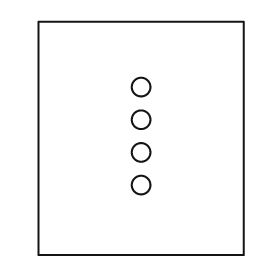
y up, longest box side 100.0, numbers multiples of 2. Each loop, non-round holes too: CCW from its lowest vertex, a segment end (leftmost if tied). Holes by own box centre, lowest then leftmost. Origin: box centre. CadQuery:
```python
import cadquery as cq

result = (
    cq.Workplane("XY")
    .moveTo(-44.0, -50.0)
    .lineTo(44.0, -50.0)
    .lineTo(44.0, 50.0)
    .lineTo(-44.0, 50.0)
    .close()
    .moveTo(0.0, -20.0)
    .circle(4.0)
    .moveTo(0.0, -6.0)
    .circle(4.0)
    .moveTo(0.0, 8.0)
    .circle(4.0)
    .moveTo(0.0, 22.0)
    .circle(4.0)
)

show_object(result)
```